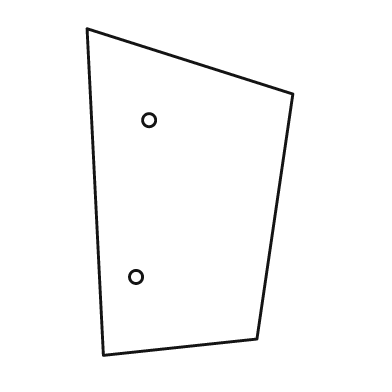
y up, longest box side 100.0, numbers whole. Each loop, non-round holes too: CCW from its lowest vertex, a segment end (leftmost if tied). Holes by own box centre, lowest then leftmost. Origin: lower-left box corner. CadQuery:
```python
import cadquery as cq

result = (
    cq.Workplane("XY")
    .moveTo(5.0, 0.0)
    .lineTo(52.0, 5.0)
    .lineTo(63.0, 80.0)
    .lineTo(0.0, 100.0)
    .close()
    .moveTo(15.0, 24.0)
    .circle(2.0)
    .moveTo(19.0, 72.0)
    .circle(2.0)
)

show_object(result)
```